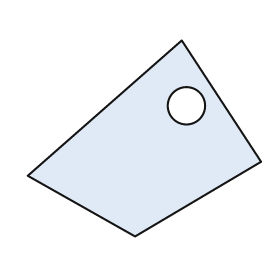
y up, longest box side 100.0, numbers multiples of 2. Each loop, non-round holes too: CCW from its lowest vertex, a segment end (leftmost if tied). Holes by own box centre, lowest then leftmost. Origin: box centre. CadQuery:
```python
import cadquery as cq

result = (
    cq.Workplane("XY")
    .moveTo(-4.0, -42.0)
    .lineTo(50.0, -10.0)
    .lineTo(16.0, 42.0)
    .lineTo(-50.0, -16.0)
    .close()
    .moveTo(18.0, 14.0)
    .circle(8.0)
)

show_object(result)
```